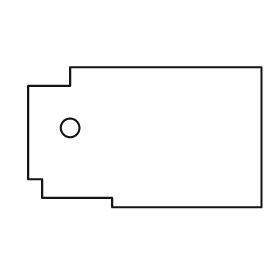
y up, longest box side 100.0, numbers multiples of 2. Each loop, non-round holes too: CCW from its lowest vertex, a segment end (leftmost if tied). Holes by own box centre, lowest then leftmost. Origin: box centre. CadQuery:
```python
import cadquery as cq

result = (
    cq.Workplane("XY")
    .moveTo(-14.0, -30.0)
    .lineTo(50.0, -30.0)
    .lineTo(50.0, 30.0)
    .lineTo(-32.0, 30.0)
    .lineTo(-32.0, 22.0)
    .lineTo(-50.0, 22.0)
    .lineTo(-50.0, -18.0)
    .lineTo(-44.0, -18.0)
    .lineTo(-44.0, -26.0)
    .lineTo(-14.0, -26.0)
    .close()
    .moveTo(-32.0, 4.0)
    .circle(4.0)
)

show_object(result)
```